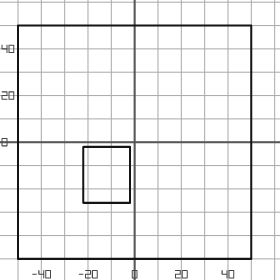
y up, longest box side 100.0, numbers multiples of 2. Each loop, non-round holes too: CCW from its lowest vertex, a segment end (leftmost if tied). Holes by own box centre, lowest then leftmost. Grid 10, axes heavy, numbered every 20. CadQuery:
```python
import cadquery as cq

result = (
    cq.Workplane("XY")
    .moveTo(-50.0, -50.0)
    .lineTo(50.0, -50.0)
    .lineTo(50.0, 50.0)
    .lineTo(-50.0, 50.0)
    .close()
    .moveTo(-22.0, -26.0)
    .lineTo(-2.0, -26.0)
    .lineTo(-2.0, -2.0)
    .lineTo(-22.0, -2.0)
    .close()
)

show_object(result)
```